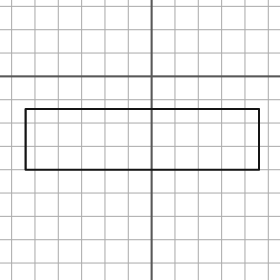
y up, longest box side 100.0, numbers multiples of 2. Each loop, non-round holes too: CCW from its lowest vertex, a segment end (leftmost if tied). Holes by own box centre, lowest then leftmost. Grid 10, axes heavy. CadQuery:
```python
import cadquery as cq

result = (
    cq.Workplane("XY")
    .moveTo(-54.0, -40.0)
    .lineTo(46.0, -40.0)
    .lineTo(46.0, -14.0)
    .lineTo(-54.0, -14.0)
    .close()
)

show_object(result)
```